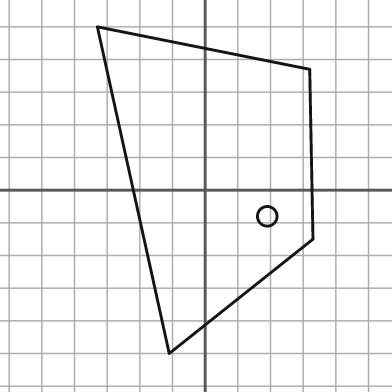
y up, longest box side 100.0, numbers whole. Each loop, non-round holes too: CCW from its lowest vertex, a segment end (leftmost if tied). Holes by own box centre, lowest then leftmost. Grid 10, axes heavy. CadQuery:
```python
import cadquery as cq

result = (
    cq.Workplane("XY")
    .moveTo(-11.0, -50.0)
    .lineTo(33.0, -15.0)
    .lineTo(32.0, 37.0)
    .lineTo(-33.0, 50.0)
    .close()
    .moveTo(19.0, -8.0)
    .circle(3.0)
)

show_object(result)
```